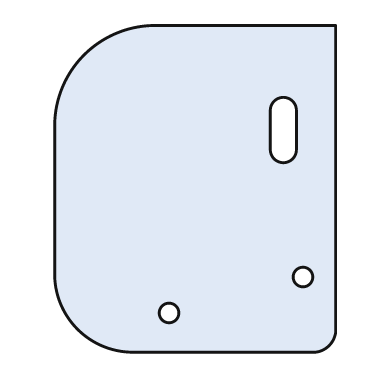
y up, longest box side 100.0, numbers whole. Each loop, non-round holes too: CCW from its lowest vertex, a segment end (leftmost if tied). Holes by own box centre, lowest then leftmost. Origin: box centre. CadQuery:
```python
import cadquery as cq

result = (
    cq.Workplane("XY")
    .moveTo(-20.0, -50.0)
    .lineTo(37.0, -50.0)
    .threePointArc((41.0, -48.0), (43.0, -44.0))
    .lineTo(43.0, 50.0)
    .lineTo(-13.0, 50.0)
    .threePointArc((-34.0, 41.0), (-43.0, 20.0))
    .lineTo(-43.0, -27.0)
    .threePointArc((-36.0, -43.0), (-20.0, -50.0))
    .close()
    .moveTo(-8.0, -38.0)
    .circle(3.0)
    .moveTo(33.0, -27.0)
    .circle(3.0)
    .moveTo(23.0, 12.0)
    .threePointArc((27.0, 8.0), (31.0, 12.0))
    .lineTo(31.0, 24.0)
    .threePointArc((27.0, 28.0), (23.0, 24.0))
    .close()
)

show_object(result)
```